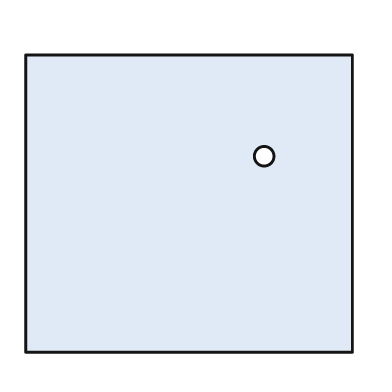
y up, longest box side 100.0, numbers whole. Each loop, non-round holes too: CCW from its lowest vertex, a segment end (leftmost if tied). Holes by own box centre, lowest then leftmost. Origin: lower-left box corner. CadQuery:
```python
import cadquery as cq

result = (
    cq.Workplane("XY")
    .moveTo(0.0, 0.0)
    .lineTo(100.0, 0.0)
    .lineTo(100.0, 91.0)
    .lineTo(0.0, 91.0)
    .close()
    .moveTo(73.0, 60.0)
    .circle(3.0)
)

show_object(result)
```